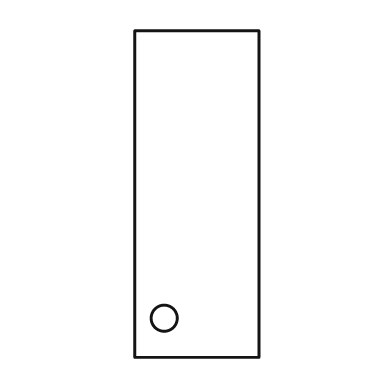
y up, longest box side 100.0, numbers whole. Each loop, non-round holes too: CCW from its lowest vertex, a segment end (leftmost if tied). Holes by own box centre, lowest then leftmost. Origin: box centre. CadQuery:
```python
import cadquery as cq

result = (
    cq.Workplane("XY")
    .moveTo(-19.0, -50.0)
    .lineTo(19.0, -50.0)
    .lineTo(19.0, 50.0)
    .lineTo(-19.0, 50.0)
    .close()
    .moveTo(-10.0, -38.0)
    .circle(4.0)
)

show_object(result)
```